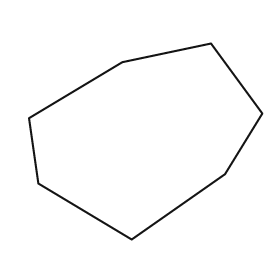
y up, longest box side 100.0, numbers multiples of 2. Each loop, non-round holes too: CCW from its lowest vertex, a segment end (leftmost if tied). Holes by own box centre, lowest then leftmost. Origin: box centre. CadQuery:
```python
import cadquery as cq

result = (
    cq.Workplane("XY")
    .moveTo(-6.0, -42.0)
    .lineTo(34.0, -14.0)
    .lineTo(50.0, 12.0)
    .lineTo(28.0, 42.0)
    .lineTo(-10.0, 34.0)
    .lineTo(-50.0, 10.0)
    .lineTo(-46.0, -18.0)
    .close()
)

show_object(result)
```